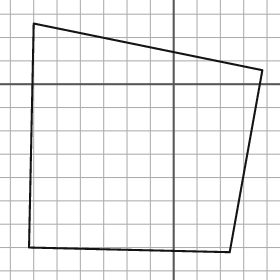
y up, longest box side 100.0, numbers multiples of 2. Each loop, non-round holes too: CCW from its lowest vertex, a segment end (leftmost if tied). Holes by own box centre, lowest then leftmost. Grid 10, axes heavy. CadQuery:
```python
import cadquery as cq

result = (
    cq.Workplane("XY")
    .moveTo(24.0, -72.0)
    .lineTo(38.0, 6.0)
    .lineTo(-60.0, 26.0)
    .lineTo(-62.0, -70.0)
    .close()
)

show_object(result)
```